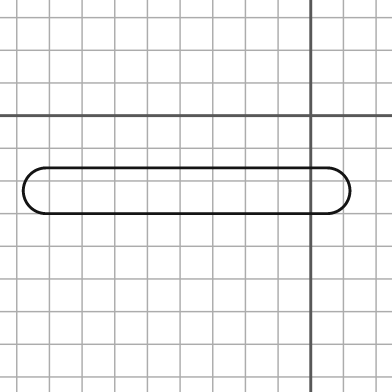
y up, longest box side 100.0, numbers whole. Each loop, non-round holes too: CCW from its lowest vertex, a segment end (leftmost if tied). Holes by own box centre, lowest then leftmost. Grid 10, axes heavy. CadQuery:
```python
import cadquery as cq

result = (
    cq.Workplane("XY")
    .moveTo(-81.0, -30.0)
    .lineTo(5.0, -30.0)
    .threePointArc((12.0, -23.0), (5.0, -16.0))
    .lineTo(-81.0, -16.0)
    .threePointArc((-88.0, -23.0), (-81.0, -30.0))
    .close()
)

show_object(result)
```